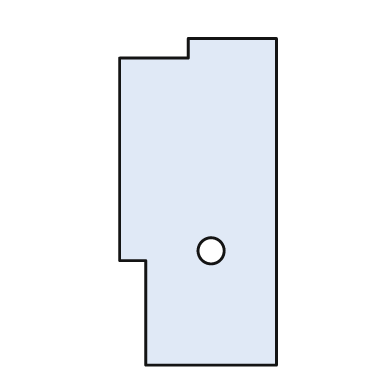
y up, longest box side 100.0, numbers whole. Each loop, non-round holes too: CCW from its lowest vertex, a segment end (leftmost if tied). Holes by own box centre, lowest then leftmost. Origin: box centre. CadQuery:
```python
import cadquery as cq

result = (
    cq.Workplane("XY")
    .moveTo(-16.0, -50.0)
    .lineTo(24.0, -50.0)
    .lineTo(24.0, 50.0)
    .lineTo(-3.0, 50.0)
    .lineTo(-3.0, 44.0)
    .lineTo(-24.0, 44.0)
    .lineTo(-24.0, -18.0)
    .lineTo(-16.0, -18.0)
    .close()
    .moveTo(4.0, -15.0)
    .circle(4.0)
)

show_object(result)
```